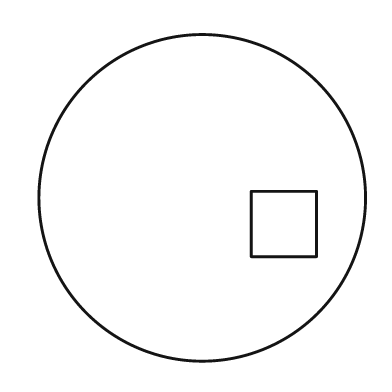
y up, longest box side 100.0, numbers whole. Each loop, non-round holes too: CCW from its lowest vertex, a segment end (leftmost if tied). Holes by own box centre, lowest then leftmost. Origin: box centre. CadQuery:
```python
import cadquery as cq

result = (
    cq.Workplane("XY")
    .moveTo(0.0, 0.0)
    .circle(50.0)
    .moveTo(15.0, -18.0)
    .lineTo(35.0, -18.0)
    .lineTo(35.0, 2.0)
    .lineTo(15.0, 2.0)
    .close()
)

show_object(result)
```